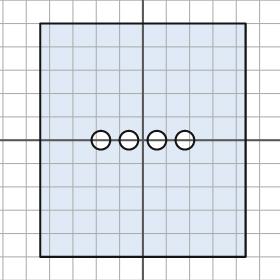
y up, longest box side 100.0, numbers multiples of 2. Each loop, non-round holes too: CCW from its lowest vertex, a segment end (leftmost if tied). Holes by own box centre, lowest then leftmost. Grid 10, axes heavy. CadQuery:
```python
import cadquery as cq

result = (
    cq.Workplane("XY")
    .moveTo(-44.0, -50.0)
    .lineTo(44.0, -50.0)
    .lineTo(44.0, 50.0)
    .lineTo(-44.0, 50.0)
    .close()
    .moveTo(-18.0, 0.0)
    .circle(4.0)
    .moveTo(-6.0, 0.0)
    .circle(4.0)
    .moveTo(6.0, 0.0)
    .circle(4.0)
    .moveTo(18.0, 0.0)
    .circle(4.0)
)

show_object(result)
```